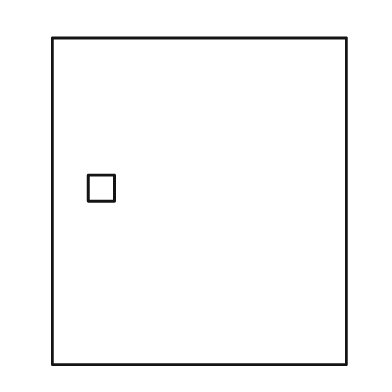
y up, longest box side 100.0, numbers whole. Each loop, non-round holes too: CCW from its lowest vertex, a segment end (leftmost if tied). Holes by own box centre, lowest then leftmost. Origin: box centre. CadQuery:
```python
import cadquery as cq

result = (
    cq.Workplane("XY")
    .moveTo(-45.0, -50.0)
    .lineTo(45.0, -50.0)
    .lineTo(45.0, 50.0)
    .lineTo(-45.0, 50.0)
    .close()
    .moveTo(-34.0, 0.0)
    .lineTo(-26.0, 0.0)
    .lineTo(-26.0, 8.0)
    .lineTo(-34.0, 8.0)
    .close()
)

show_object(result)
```